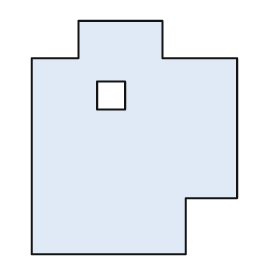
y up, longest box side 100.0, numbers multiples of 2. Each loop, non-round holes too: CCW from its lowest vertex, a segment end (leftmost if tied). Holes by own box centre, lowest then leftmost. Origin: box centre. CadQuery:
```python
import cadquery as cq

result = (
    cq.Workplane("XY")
    .moveTo(-44.0, -50.0)
    .lineTo(22.0, -50.0)
    .lineTo(22.0, -26.0)
    .lineTo(44.0, -26.0)
    .lineTo(44.0, 34.0)
    .lineTo(12.0, 34.0)
    .lineTo(12.0, 50.0)
    .lineTo(-24.0, 50.0)
    .lineTo(-24.0, 34.0)
    .lineTo(-44.0, 34.0)
    .close()
    .moveTo(-16.0, 12.0)
    .lineTo(-4.0, 12.0)
    .lineTo(-4.0, 24.0)
    .lineTo(-16.0, 24.0)
    .close()
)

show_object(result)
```